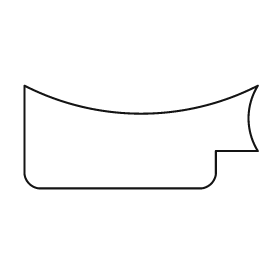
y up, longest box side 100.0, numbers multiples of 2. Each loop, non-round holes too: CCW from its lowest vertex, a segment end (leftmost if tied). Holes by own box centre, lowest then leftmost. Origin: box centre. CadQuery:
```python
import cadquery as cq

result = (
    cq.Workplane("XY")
    .moveTo(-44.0, -22.0)
    .lineTo(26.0, -22.0)
    .threePointArc((30.0, -20.0), (32.0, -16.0))
    .lineTo(32.0, -6.0)
    .lineTo(50.0, -6.0)
    .threePointArc((46.0, 8.0), (50.0, 22.0))
    .threePointArc((0.0, 10.0), (-50.0, 22.0))
    .lineTo(-50.0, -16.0)
    .threePointArc((-48.0, -20.0), (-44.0, -22.0))
    .close()
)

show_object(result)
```